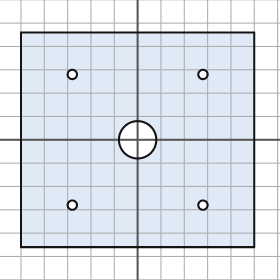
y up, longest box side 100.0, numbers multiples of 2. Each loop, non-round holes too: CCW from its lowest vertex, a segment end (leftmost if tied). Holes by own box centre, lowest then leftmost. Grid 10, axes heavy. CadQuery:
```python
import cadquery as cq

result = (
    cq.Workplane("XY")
    .moveTo(-50.0, -46.0)
    .lineTo(50.0, -46.0)
    .lineTo(50.0, 46.0)
    .lineTo(-50.0, 46.0)
    .close()
    .moveTo(-28.0, -28.0)
    .circle(2.0)
    .moveTo(28.0, -28.0)
    .circle(2.0)
    .moveTo(0.0, 0.0)
    .circle(8.0)
    .moveTo(-28.0, 28.0)
    .circle(2.0)
    .moveTo(28.0, 28.0)
    .circle(2.0)
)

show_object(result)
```